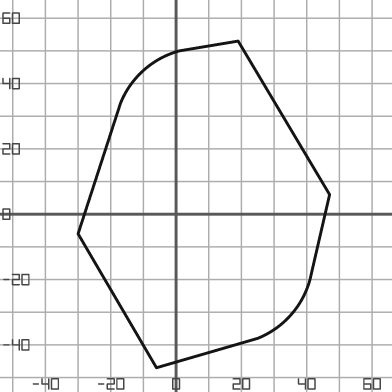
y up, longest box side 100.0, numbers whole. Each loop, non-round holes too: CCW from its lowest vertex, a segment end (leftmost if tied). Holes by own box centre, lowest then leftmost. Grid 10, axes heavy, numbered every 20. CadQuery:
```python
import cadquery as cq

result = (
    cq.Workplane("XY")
    .moveTo(-6.0, -47.0)
    .lineTo(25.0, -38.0)
    .threePointArc((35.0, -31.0), (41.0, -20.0))
    .lineTo(47.0, 6.0)
    .lineTo(19.0, 53.0)
    .lineTo(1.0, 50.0)
    .threePointArc((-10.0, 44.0), (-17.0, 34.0))
    .lineTo(-30.0, -6.0)
    .close()
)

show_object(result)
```